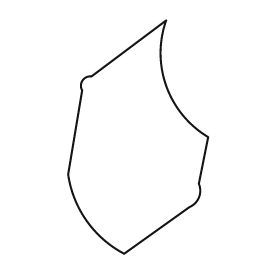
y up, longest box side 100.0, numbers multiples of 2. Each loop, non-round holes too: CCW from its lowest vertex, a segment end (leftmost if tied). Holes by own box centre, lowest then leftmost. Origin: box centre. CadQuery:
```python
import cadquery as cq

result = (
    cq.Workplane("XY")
    .moveTo(-6.0, -50.0)
    .lineTo(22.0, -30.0)
    .threePointArc((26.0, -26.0), (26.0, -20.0))
    .lineTo(30.0, 0.0)
    .threePointArc((12.0, 22.0), (12.0, 50.0))
    .lineTo(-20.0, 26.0)
    .threePointArc((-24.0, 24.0), (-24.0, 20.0))
    .lineTo(-30.0, -16.0)
    .threePointArc((-22.0, -36.0), (-6.0, -50.0))
    .close()
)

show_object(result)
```